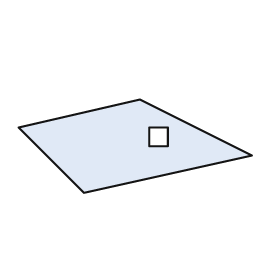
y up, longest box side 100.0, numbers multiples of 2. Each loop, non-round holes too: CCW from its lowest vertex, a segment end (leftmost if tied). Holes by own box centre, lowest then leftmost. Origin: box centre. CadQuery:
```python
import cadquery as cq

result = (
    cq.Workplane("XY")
    .moveTo(-22.0, -20.0)
    .lineTo(50.0, -4.0)
    .lineTo(2.0, 20.0)
    .lineTo(-50.0, 8.0)
    .close()
    .moveTo(6.0, 0.0)
    .lineTo(14.0, 0.0)
    .lineTo(14.0, 8.0)
    .lineTo(6.0, 8.0)
    .close()
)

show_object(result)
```